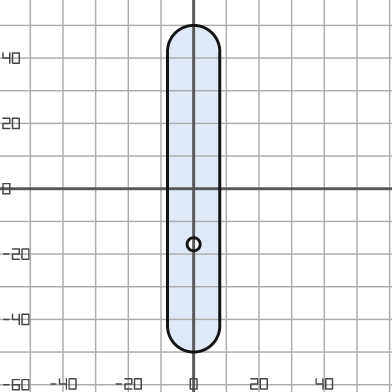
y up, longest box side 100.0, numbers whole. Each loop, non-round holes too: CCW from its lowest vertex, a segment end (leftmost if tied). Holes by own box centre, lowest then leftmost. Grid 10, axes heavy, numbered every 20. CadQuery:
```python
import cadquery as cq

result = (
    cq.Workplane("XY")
    .moveTo(-8.0, -42.0)
    .threePointArc((0.0, -50.0), (8.0, -42.0))
    .lineTo(8.0, 42.0)
    .threePointArc((0.0, 50.0), (-8.0, 42.0))
    .close()
    .moveTo(0.0, -17.0)
    .circle(2.0)
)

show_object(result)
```